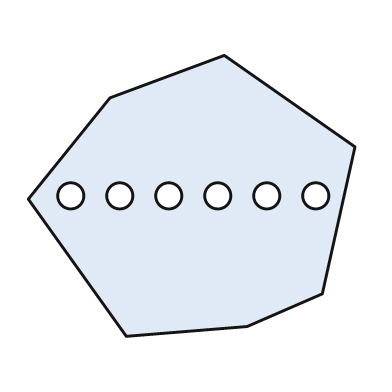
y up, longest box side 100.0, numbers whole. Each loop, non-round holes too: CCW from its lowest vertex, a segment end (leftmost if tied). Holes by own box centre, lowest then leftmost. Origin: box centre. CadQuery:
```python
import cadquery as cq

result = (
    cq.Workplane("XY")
    .moveTo(-20.0, -43.0)
    .lineTo(17.0, -40.0)
    .lineTo(40.0, -30.0)
    .lineTo(50.0, 15.0)
    .lineTo(10.0, 43.0)
    .lineTo(-25.0, 30.0)
    .lineTo(-50.0, -1.0)
    .close()
    .moveTo(-37.0, 0.0)
    .circle(4.0)
    .moveTo(-22.0, 0.0)
    .circle(4.0)
    .moveTo(-7.0, 0.0)
    .circle(4.0)
    .moveTo(8.0, 0.0)
    .circle(4.0)
    .moveTo(23.0, 0.0)
    .circle(4.0)
    .moveTo(38.0, 0.0)
    .circle(4.0)
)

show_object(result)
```